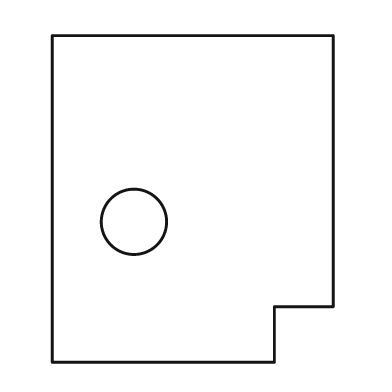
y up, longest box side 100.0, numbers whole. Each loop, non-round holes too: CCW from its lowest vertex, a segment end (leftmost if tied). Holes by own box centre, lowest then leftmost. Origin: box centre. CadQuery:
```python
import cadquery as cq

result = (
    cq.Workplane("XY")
    .moveTo(-43.0, -50.0)
    .lineTo(25.0, -50.0)
    .lineTo(25.0, -33.0)
    .lineTo(43.0, -33.0)
    .lineTo(43.0, 50.0)
    .lineTo(-43.0, 50.0)
    .close()
    .moveTo(-18.0, -7.0)
    .circle(10.0)
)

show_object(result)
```